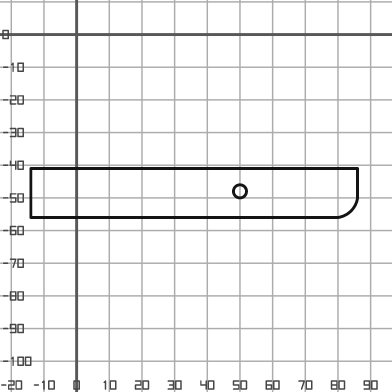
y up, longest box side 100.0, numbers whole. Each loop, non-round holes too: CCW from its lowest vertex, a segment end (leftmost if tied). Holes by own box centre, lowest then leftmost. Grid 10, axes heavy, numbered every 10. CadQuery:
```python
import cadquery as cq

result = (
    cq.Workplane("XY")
    .moveTo(-14.0, -56.0)
    .lineTo(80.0, -56.0)
    .threePointArc((84.0, -54.0), (86.0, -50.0))
    .lineTo(86.0, -41.0)
    .lineTo(-14.0, -41.0)
    .close()
    .moveTo(50.0, -48.0)
    .circle(2.0)
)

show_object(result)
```